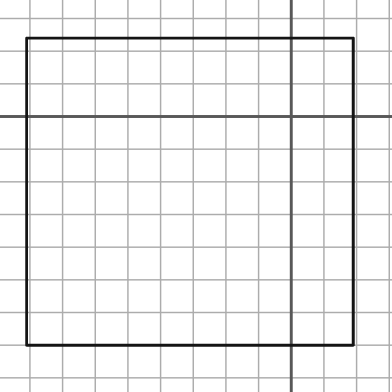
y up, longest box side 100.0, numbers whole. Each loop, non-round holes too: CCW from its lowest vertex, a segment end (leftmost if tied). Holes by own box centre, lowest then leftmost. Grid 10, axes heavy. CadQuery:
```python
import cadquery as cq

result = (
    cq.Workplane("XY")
    .moveTo(-81.0, -70.0)
    .lineTo(19.0, -70.0)
    .lineTo(19.0, 24.0)
    .lineTo(-81.0, 24.0)
    .close()
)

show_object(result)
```